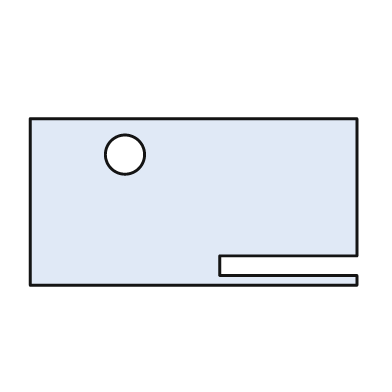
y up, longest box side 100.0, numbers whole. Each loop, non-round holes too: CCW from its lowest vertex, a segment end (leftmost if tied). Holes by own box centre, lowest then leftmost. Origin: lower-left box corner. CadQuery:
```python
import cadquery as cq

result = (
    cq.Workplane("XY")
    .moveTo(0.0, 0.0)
    .lineTo(100.0, 0.0)
    .lineTo(100.0, 3.0)
    .lineTo(58.0, 3.0)
    .lineTo(58.0, 9.0)
    .lineTo(100.0, 9.0)
    .lineTo(100.0, 51.0)
    .lineTo(0.0, 51.0)
    .close()
    .moveTo(29.0, 40.0)
    .circle(6.0)
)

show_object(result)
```